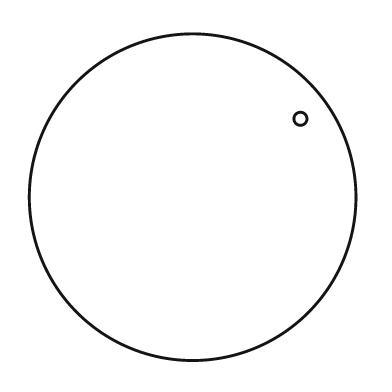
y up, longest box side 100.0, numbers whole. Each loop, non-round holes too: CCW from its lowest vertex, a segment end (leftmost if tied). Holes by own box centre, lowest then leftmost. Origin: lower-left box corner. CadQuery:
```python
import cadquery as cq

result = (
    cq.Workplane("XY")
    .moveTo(50.0, 50.0)
    .circle(50.0)
    .moveTo(83.0, 74.0)
    .circle(2.0)
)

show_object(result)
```